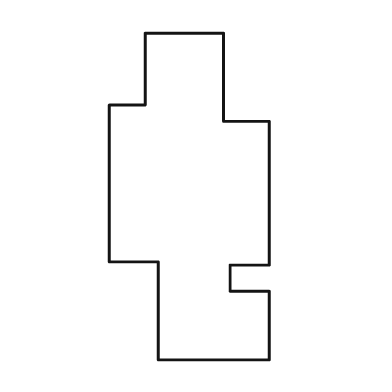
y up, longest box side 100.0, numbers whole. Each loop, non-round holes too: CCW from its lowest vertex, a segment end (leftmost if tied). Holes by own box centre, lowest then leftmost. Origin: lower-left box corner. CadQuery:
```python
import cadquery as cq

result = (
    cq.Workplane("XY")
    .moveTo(15.0, 0.0)
    .lineTo(49.0, 0.0)
    .lineTo(49.0, 21.0)
    .lineTo(37.0, 21.0)
    .lineTo(37.0, 29.0)
    .lineTo(49.0, 29.0)
    .lineTo(49.0, 73.0)
    .lineTo(35.0, 73.0)
    .lineTo(35.0, 100.0)
    .lineTo(11.0, 100.0)
    .lineTo(11.0, 78.0)
    .lineTo(0.0, 78.0)
    .lineTo(0.0, 30.0)
    .lineTo(15.0, 30.0)
    .close()
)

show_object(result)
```